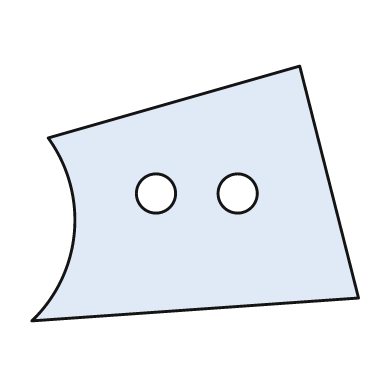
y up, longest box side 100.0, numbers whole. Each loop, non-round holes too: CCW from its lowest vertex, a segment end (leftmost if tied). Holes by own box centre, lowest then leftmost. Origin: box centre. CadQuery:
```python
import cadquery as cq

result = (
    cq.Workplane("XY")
    .moveTo(-50.0, -39.0)
    .lineTo(50.0, -32.0)
    .lineTo(32.0, 39.0)
    .lineTo(-45.0, 17.0)
    .threePointArc((-37.0, -12.0), (-50.0, -39.0))
    .close()
    .moveTo(-12.0, 0.0)
    .circle(6.0)
    .moveTo(13.0, 0.0)
    .circle(6.0)
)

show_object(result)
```